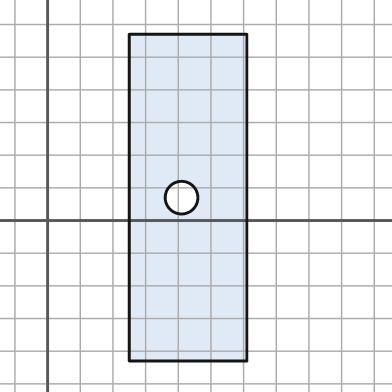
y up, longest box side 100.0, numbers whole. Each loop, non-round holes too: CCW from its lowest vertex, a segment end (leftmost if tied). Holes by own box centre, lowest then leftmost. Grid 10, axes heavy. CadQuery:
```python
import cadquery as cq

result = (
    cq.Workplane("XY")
    .moveTo(25.0, -43.0)
    .lineTo(61.0, -43.0)
    .lineTo(61.0, 57.0)
    .lineTo(25.0, 57.0)
    .close()
    .moveTo(41.0, 7.0)
    .circle(5.0)
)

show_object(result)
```